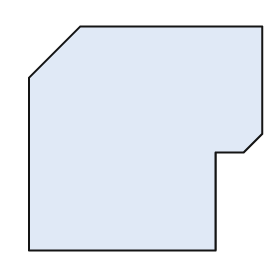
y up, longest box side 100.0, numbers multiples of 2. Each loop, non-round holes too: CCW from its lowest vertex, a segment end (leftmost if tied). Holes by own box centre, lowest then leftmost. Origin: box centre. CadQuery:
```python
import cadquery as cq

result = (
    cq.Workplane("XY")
    .moveTo(-50.0, -48.0)
    .lineTo(30.0, -48.0)
    .lineTo(30.0, -6.0)
    .lineTo(42.0, -6.0)
    .lineTo(50.0, 2.0)
    .lineTo(50.0, 48.0)
    .lineTo(-28.0, 48.0)
    .lineTo(-50.0, 26.0)
    .close()
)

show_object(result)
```